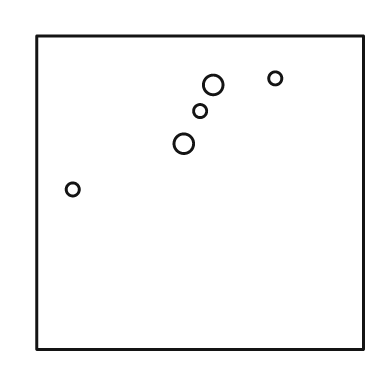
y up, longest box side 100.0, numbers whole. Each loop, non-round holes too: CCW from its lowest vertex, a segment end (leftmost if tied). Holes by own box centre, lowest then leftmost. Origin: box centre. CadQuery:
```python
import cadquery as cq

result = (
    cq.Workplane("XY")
    .moveTo(-50.0, -48.0)
    .lineTo(50.0, -48.0)
    .lineTo(50.0, 48.0)
    .lineTo(-50.0, 48.0)
    .close()
    .moveTo(-39.0, 1.0)
    .circle(2.0)
    .moveTo(-5.0, 15.0)
    .circle(3.0)
    .moveTo(0.0, 25.0)
    .circle(2.0)
    .moveTo(4.0, 33.0)
    .circle(3.0)
    .moveTo(23.0, 35.0)
    .circle(2.0)
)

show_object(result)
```